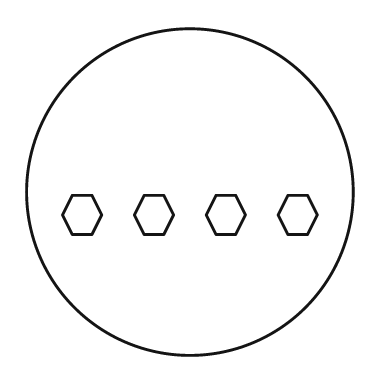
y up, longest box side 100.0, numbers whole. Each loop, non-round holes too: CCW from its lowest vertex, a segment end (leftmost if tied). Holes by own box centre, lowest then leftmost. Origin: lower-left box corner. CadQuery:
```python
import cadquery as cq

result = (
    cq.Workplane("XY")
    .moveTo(50.0, 50.0)
    .circle(50.0)
    .moveTo(14.0, 37.0)
    .lineTo(20.0, 37.0)
    .lineTo(23.0, 43.0)
    .lineTo(20.0, 49.0)
    .lineTo(14.0, 49.0)
    .lineTo(11.0, 43.0)
    .close()
    .moveTo(36.0, 37.0)
    .lineTo(42.0, 37.0)
    .lineTo(45.0, 43.0)
    .lineTo(42.0, 49.0)
    .lineTo(36.0, 49.0)
    .lineTo(33.0, 43.0)
    .close()
    .moveTo(58.0, 37.0)
    .lineTo(64.0, 37.0)
    .lineTo(67.0, 43.0)
    .lineTo(64.0, 49.0)
    .lineTo(58.0, 49.0)
    .lineTo(55.0, 43.0)
    .close()
    .moveTo(80.0, 37.0)
    .lineTo(86.0, 37.0)
    .lineTo(89.0, 43.0)
    .lineTo(86.0, 49.0)
    .lineTo(80.0, 49.0)
    .lineTo(77.0, 43.0)
    .close()
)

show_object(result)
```